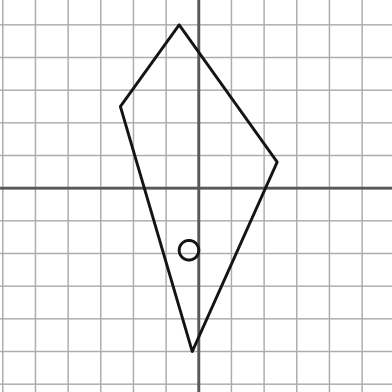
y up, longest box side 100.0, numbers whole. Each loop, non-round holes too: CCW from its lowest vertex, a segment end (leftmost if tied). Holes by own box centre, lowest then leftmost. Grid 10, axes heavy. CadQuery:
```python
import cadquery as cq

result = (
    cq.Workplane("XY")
    .moveTo(-2.0, -50.0)
    .lineTo(24.0, 8.0)
    .lineTo(-6.0, 50.0)
    .lineTo(-24.0, 25.0)
    .close()
    .moveTo(-3.0, -19.0)
    .circle(3.0)
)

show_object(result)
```